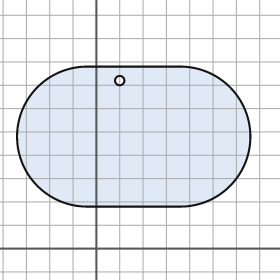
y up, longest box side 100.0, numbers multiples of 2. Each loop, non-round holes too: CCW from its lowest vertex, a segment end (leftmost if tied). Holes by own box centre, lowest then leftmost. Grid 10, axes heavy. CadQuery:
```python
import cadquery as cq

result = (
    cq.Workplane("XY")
    .moveTo(-4.0, 18.0)
    .lineTo(36.0, 18.0)
    .threePointArc((66.0, 48.0), (36.0, 78.0))
    .lineTo(-4.0, 78.0)
    .threePointArc((-34.0, 48.0), (-4.0, 18.0))
    .close()
    .moveTo(10.0, 72.0)
    .circle(2.0)
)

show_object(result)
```